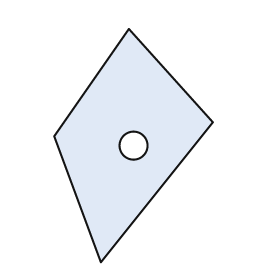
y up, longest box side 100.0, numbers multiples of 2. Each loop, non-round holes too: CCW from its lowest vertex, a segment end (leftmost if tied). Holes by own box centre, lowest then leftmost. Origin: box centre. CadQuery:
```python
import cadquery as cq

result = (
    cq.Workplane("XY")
    .moveTo(-14.0, -50.0)
    .lineTo(34.0, 10.0)
    .lineTo(-2.0, 50.0)
    .lineTo(-34.0, 4.0)
    .close()
    .moveTo(0.0, 0.0)
    .circle(6.0)
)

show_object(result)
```